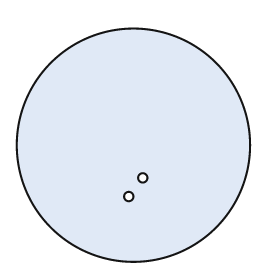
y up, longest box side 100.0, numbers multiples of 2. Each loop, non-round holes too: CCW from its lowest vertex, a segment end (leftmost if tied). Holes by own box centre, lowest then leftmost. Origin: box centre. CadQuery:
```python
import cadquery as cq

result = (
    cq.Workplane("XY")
    .moveTo(0.0, 0.0)
    .circle(50.0)
    .moveTo(-2.0, -22.0)
    .circle(2.0)
    .moveTo(4.0, -14.0)
    .circle(2.0)
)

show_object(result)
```